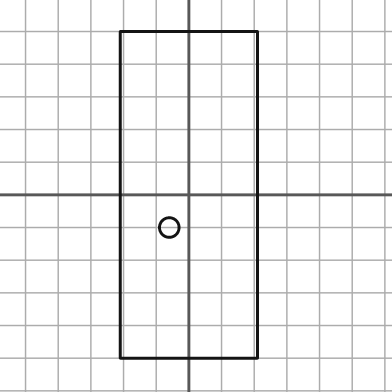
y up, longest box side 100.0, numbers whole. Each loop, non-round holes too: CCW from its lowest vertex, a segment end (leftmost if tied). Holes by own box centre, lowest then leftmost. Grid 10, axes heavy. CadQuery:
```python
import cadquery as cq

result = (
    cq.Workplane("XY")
    .moveTo(-21.0, -50.0)
    .lineTo(21.0, -50.0)
    .lineTo(21.0, 50.0)
    .lineTo(-21.0, 50.0)
    .close()
    .moveTo(-6.0, -10.0)
    .circle(3.0)
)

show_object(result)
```